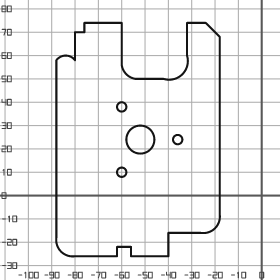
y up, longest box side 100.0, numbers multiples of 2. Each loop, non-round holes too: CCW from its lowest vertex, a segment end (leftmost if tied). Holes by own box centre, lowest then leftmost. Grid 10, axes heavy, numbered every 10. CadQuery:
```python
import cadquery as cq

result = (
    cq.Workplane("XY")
    .moveTo(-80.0, -26.0)
    .lineTo(-62.0, -26.0)
    .lineTo(-62.0, -22.0)
    .lineTo(-56.0, -22.0)
    .lineTo(-56.0, -26.0)
    .lineTo(-40.0, -26.0)
    .lineTo(-40.0, -16.0)
    .lineTo(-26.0, -16.0)
    .threePointArc((-20.0, -14.0), (-18.0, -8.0))
    .lineTo(-18.0, 68.0)
    .lineTo(-24.0, 74.0)
    .lineTo(-32.0, 74.0)
    .lineTo(-32.0, 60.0)
    .threePointArc((-34.0, 52.0), (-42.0, 50.0))
    .lineTo(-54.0, 50.0)
    .threePointArc((-58.0, 52.0), (-60.0, 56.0))
    .lineTo(-60.0, 74.0)
    .lineTo(-76.0, 74.0)
    .lineTo(-76.0, 70.0)
    .lineTo(-80.0, 70.0)
    .lineTo(-80.0, 58.0)
    .threePointArc((-84.0, 60.0), (-88.0, 58.0))
    .lineTo(-88.0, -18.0)
    .threePointArc((-86.0, -24.0), (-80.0, -26.0))
    .close()
    .moveTo(-60.0, 10.0)
    .circle(2.0)
    .moveTo(-52.0, 24.0)
    .circle(6.0)
    .moveTo(-36.0, 24.0)
    .circle(2.0)
    .moveTo(-60.0, 38.0)
    .circle(2.0)
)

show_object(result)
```